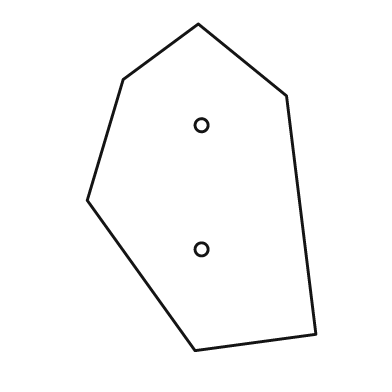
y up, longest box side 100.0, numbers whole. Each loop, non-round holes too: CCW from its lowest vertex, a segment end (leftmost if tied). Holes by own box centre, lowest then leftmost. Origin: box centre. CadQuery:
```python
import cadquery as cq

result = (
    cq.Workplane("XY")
    .moveTo(-2.0, -50.0)
    .lineTo(35.0, -45.0)
    .lineTo(26.0, 28.0)
    .lineTo(-1.0, 50.0)
    .lineTo(-24.0, 33.0)
    .lineTo(-35.0, -4.0)
    .close()
    .moveTo(0.0, -19.0)
    .circle(2.0)
    .moveTo(0.0, 19.0)
    .circle(2.0)
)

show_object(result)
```